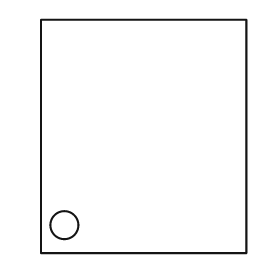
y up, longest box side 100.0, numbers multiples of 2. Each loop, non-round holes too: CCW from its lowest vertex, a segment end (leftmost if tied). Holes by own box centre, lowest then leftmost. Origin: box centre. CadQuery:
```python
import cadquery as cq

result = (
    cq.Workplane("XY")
    .moveTo(-44.0, -50.0)
    .lineTo(44.0, -50.0)
    .lineTo(44.0, 50.0)
    .lineTo(-44.0, 50.0)
    .close()
    .moveTo(-34.0, -38.0)
    .circle(6.0)
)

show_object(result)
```